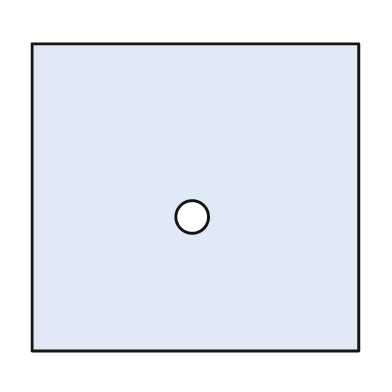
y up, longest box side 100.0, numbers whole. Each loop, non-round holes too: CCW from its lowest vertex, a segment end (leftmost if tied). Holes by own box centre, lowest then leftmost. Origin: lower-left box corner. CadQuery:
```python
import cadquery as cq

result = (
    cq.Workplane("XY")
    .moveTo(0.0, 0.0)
    .lineTo(100.0, 0.0)
    .lineTo(100.0, 94.0)
    .lineTo(0.0, 94.0)
    .close()
    .moveTo(49.0, 41.0)
    .circle(5.0)
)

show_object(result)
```